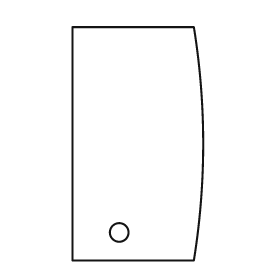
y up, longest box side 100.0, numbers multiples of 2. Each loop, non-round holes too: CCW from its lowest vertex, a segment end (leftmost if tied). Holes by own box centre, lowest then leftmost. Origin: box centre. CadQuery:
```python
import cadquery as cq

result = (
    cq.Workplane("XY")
    .moveTo(-28.0, -50.0)
    .lineTo(24.0, -50.0)
    .threePointArc((28.0, 0.0), (24.0, 50.0))
    .lineTo(-28.0, 50.0)
    .close()
    .moveTo(-8.0, -38.0)
    .circle(4.0)
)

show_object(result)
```